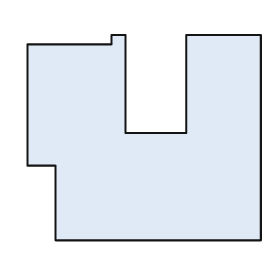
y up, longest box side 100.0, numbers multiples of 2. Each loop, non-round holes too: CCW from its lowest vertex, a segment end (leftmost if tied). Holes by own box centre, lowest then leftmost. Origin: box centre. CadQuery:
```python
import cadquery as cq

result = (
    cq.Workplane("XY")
    .moveTo(-38.0, -44.0)
    .lineTo(50.0, -44.0)
    .lineTo(50.0, 44.0)
    .lineTo(18.0, 44.0)
    .lineTo(18.0, 2.0)
    .lineTo(-8.0, 2.0)
    .lineTo(-8.0, 44.0)
    .lineTo(-14.0, 44.0)
    .lineTo(-14.0, 40.0)
    .lineTo(-50.0, 40.0)
    .lineTo(-50.0, -12.0)
    .lineTo(-38.0, -12.0)
    .close()
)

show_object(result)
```